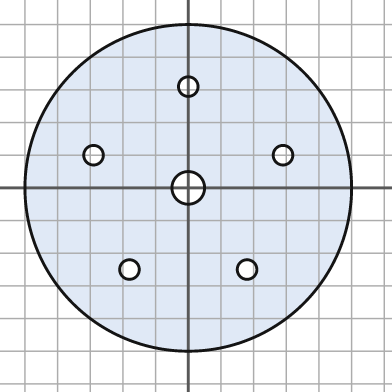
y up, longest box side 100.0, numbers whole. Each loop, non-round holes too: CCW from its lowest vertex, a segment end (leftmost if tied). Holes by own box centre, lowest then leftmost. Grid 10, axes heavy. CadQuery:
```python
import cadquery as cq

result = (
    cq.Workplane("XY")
    .moveTo(0.0, 0.0)
    .circle(50.0)
    .moveTo(-18.0, -25.0)
    .circle(3.0)
    .moveTo(18.0, -25.0)
    .circle(3.0)
    .moveTo(0.0, 0.0)
    .circle(5.0)
    .moveTo(-29.0, 10.0)
    .circle(3.0)
    .moveTo(29.0, 10.0)
    .circle(3.0)
    .moveTo(0.0, 31.0)
    .circle(3.0)
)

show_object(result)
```